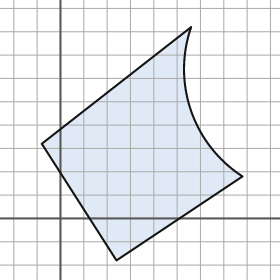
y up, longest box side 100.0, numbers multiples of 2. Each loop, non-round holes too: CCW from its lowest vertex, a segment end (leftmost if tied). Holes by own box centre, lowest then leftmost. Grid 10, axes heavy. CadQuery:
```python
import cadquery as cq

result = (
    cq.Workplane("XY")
    .moveTo(24.0, -18.0)
    .lineTo(78.0, 18.0)
    .threePointArc((56.0, 46.0), (56.0, 82.0))
    .lineTo(-8.0, 32.0)
    .close()
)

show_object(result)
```